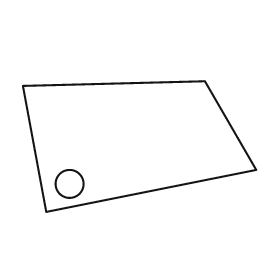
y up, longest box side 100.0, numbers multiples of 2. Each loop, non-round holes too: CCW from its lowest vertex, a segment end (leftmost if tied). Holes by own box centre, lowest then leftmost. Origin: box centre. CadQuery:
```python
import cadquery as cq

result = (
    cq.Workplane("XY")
    .moveTo(-40.0, -28.0)
    .lineTo(50.0, -10.0)
    .lineTo(28.0, 28.0)
    .lineTo(-50.0, 26.0)
    .close()
    .moveTo(-30.0, -16.0)
    .circle(6.0)
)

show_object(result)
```